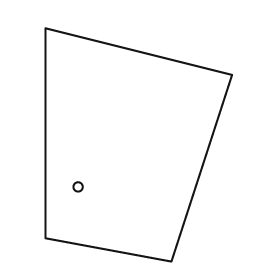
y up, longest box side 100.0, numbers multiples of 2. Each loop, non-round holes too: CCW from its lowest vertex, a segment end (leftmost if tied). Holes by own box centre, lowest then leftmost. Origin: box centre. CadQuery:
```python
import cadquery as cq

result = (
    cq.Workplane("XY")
    .moveTo(14.0, -50.0)
    .lineTo(40.0, 30.0)
    .lineTo(-40.0, 50.0)
    .lineTo(-40.0, -40.0)
    .close()
    .moveTo(-26.0, -18.0)
    .circle(2.0)
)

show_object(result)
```